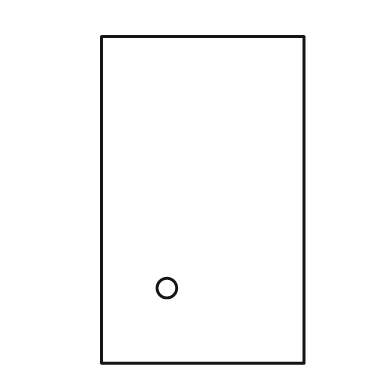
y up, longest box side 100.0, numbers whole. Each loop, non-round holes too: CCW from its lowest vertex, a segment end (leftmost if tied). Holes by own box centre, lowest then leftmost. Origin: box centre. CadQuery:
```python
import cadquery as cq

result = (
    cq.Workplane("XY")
    .moveTo(-31.0, -50.0)
    .lineTo(31.0, -50.0)
    .lineTo(31.0, 50.0)
    .lineTo(-31.0, 50.0)
    .close()
    .moveTo(-11.0, -27.0)
    .circle(3.0)
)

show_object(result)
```